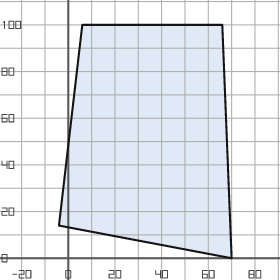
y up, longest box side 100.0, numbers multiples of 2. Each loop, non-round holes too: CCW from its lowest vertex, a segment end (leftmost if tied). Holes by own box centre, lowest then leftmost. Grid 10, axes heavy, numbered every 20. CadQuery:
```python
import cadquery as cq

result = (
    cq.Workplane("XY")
    .moveTo(70.0, 0.0)
    .lineTo(66.0, 100.0)
    .lineTo(6.0, 100.0)
    .lineTo(-4.0, 14.0)
    .close()
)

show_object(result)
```